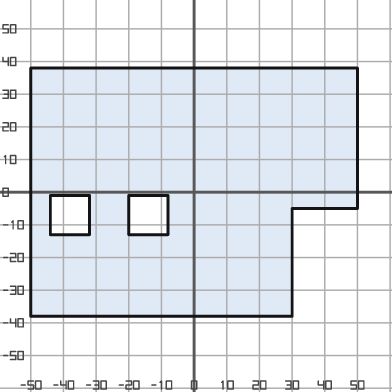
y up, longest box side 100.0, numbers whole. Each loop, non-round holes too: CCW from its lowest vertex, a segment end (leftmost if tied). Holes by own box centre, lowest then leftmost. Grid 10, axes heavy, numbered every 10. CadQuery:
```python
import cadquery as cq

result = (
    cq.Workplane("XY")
    .moveTo(-50.0, -38.0)
    .lineTo(30.0, -38.0)
    .lineTo(30.0, -5.0)
    .lineTo(50.0, -5.0)
    .lineTo(50.0, 38.0)
    .lineTo(-50.0, 38.0)
    .close()
    .moveTo(-44.0, -13.0)
    .lineTo(-32.0, -13.0)
    .lineTo(-32.0, -1.0)
    .lineTo(-44.0, -1.0)
    .close()
    .moveTo(-20.0, -13.0)
    .lineTo(-8.0, -13.0)
    .lineTo(-8.0, -1.0)
    .lineTo(-20.0, -1.0)
    .close()
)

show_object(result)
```